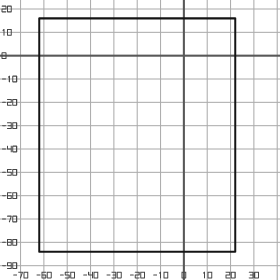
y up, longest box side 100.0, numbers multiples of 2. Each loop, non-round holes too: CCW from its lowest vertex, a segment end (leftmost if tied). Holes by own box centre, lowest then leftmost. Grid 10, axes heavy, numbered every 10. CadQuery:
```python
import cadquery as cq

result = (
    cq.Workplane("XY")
    .moveTo(-62.0, -84.0)
    .lineTo(22.0, -84.0)
    .lineTo(22.0, 16.0)
    .lineTo(-62.0, 16.0)
    .close()
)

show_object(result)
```